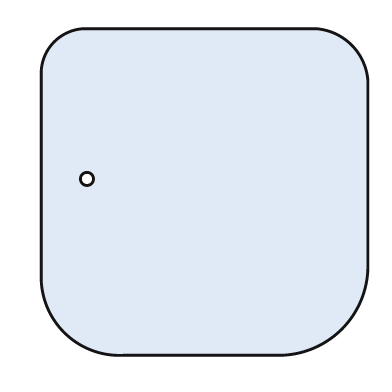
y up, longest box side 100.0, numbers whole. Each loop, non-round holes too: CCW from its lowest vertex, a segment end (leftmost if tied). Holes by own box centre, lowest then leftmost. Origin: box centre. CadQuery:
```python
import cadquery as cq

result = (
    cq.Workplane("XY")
    .moveTo(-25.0, -50.0)
    .lineTo(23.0, -50.0)
    .threePointArc((42.0, -42.0), (50.0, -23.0))
    .lineTo(50.0, 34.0)
    .threePointArc((45.0, 45.0), (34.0, 50.0))
    .lineTo(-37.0, 50.0)
    .threePointArc((-46.0, 46.0), (-50.0, 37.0))
    .lineTo(-50.0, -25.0)
    .threePointArc((-43.0, -43.0), (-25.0, -50.0))
    .close()
    .moveTo(-36.0, 4.0)
    .circle(2.0)
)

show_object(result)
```